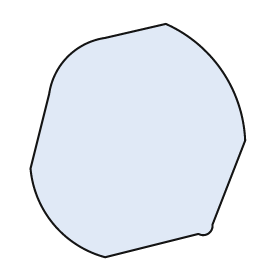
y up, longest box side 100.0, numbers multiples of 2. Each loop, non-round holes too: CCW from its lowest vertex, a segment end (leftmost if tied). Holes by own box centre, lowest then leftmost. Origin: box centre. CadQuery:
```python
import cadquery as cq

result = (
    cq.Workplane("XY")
    .moveTo(-14.0, -50.0)
    .lineTo(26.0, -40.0)
    .threePointArc((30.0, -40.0), (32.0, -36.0))
    .lineTo(46.0, 0.0)
    .threePointArc((36.0, 30.0), (12.0, 50.0))
    .lineTo(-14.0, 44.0)
    .threePointArc((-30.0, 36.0), (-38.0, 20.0))
    .lineTo(-46.0, -12.0)
    .threePointArc((-36.0, -36.0), (-14.0, -50.0))
    .close()
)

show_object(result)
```